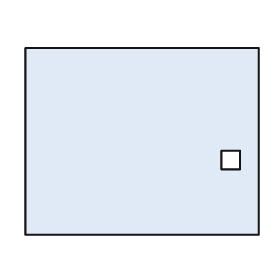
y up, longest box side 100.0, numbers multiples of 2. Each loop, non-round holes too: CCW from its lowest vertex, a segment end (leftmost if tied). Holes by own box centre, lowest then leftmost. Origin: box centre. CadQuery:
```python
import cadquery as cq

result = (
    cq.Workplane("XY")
    .moveTo(-50.0, -40.0)
    .lineTo(50.0, -40.0)
    .lineTo(50.0, 40.0)
    .lineTo(-50.0, 40.0)
    .close()
    .moveTo(34.0, -12.0)
    .lineTo(42.0, -12.0)
    .lineTo(42.0, -4.0)
    .lineTo(34.0, -4.0)
    .close()
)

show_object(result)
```